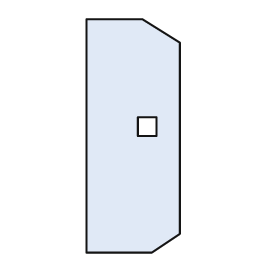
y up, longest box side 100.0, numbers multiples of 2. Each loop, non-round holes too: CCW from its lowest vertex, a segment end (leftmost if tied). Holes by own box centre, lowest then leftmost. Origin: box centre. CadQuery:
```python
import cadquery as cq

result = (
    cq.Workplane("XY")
    .moveTo(-20.0, -50.0)
    .lineTo(8.0, -50.0)
    .lineTo(20.0, -42.0)
    .lineTo(20.0, 40.0)
    .lineTo(4.0, 50.0)
    .lineTo(-20.0, 50.0)
    .close()
    .moveTo(2.0, 0.0)
    .lineTo(10.0, 0.0)
    .lineTo(10.0, 8.0)
    .lineTo(2.0, 8.0)
    .close()
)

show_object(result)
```